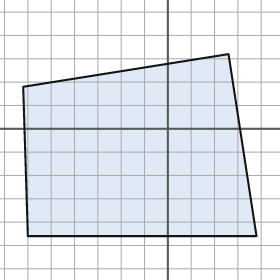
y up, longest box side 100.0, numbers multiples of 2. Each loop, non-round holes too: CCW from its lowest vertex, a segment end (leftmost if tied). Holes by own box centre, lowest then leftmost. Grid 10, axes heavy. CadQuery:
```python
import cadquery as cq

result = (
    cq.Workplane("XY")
    .moveTo(-60.0, -46.0)
    .lineTo(38.0, -46.0)
    .lineTo(26.0, 32.0)
    .lineTo(-62.0, 18.0)
    .close()
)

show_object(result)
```